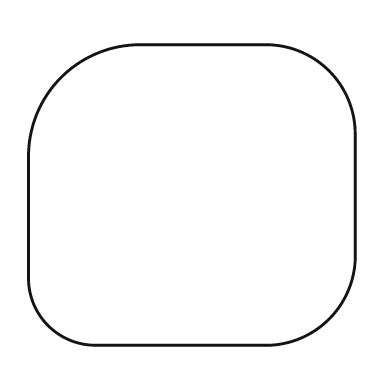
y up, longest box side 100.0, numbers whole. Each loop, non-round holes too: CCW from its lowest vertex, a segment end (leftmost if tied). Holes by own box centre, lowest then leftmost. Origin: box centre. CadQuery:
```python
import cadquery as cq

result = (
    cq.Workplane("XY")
    .moveTo(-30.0, -46.0)
    .lineTo(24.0, -46.0)
    .threePointArc((42.0, -38.0), (50.0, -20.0))
    .lineTo(50.0, 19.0)
    .threePointArc((42.0, 38.0), (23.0, 46.0))
    .lineTo(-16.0, 46.0)
    .threePointArc((-40.0, 36.0), (-50.0, 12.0))
    .lineTo(-50.0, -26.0)
    .threePointArc((-44.0, -40.0), (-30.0, -46.0))
    .close()
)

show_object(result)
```